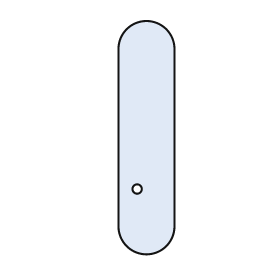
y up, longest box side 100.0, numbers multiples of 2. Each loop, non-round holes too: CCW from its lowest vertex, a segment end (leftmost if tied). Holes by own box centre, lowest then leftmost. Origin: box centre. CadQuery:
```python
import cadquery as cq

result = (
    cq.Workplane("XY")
    .moveTo(-12.0, -38.0)
    .threePointArc((0.0, -50.0), (12.0, -38.0))
    .lineTo(12.0, 38.0)
    .threePointArc((0.0, 50.0), (-12.0, 38.0))
    .close()
    .moveTo(-4.0, -22.0)
    .circle(2.0)
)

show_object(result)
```